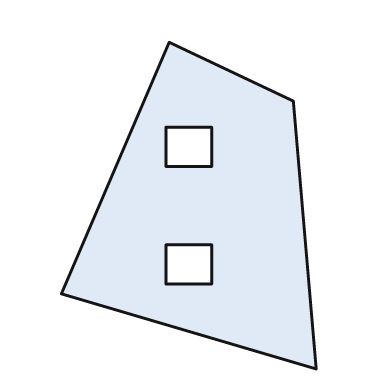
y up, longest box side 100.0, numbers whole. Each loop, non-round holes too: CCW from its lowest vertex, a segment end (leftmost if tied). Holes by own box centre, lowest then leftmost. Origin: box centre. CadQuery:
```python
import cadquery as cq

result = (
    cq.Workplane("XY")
    .moveTo(39.0, -50.0)
    .lineTo(32.0, 32.0)
    .lineTo(-6.0, 50.0)
    .lineTo(-39.0, -27.0)
    .close()
    .moveTo(-7.0, -24.0)
    .lineTo(7.0, -24.0)
    .lineTo(7.0, -12.0)
    .lineTo(-7.0, -12.0)
    .close()
    .moveTo(-7.0, 12.0)
    .lineTo(7.0, 12.0)
    .lineTo(7.0, 24.0)
    .lineTo(-7.0, 24.0)
    .close()
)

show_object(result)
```